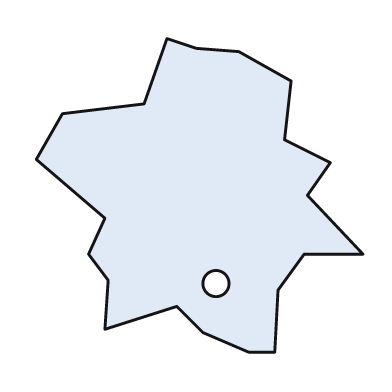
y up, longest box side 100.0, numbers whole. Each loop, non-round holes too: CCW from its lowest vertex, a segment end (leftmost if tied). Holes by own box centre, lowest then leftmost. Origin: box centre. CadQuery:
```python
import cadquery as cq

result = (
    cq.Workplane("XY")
    .moveTo(15.0, -48.0)
    .lineTo(23.0, -48.0)
    .lineTo(24.0, -29.0)
    .lineTo(32.0, -18.0)
    .lineTo(50.0, -18.0)
    .lineTo(33.0, 0.0)
    .lineTo(40.0, 10.0)
    .lineTo(26.0, 17.0)
    .lineTo(28.0, 35.0)
    .lineTo(12.0, 44.0)
    .lineTo(-1.0, 45.0)
    .lineTo(-10.0, 48.0)
    .lineTo(-17.0, 28.0)
    .lineTo(-42.0, 25.0)
    .lineTo(-50.0, 11.0)
    .lineTo(-29.0, -7.0)
    .lineTo(-34.0, -18.0)
    .lineTo(-28.0, -26.0)
    .lineTo(-29.0, -41.0)
    .lineTo(-7.0, -34.0)
    .lineTo(1.0, -42.0)
    .close()
    .moveTo(5.0, -27.0)
    .circle(4.0)
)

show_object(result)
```